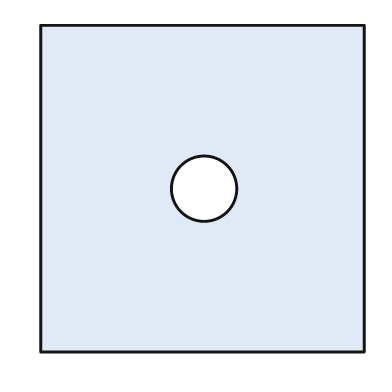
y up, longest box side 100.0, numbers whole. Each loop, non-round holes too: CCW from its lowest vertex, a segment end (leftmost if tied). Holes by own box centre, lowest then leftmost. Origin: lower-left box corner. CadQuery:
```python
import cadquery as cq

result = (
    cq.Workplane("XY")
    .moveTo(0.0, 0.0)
    .lineTo(99.0, 0.0)
    .lineTo(99.0, 100.0)
    .lineTo(0.0, 100.0)
    .close()
    .moveTo(50.0, 50.0)
    .circle(10.0)
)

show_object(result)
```